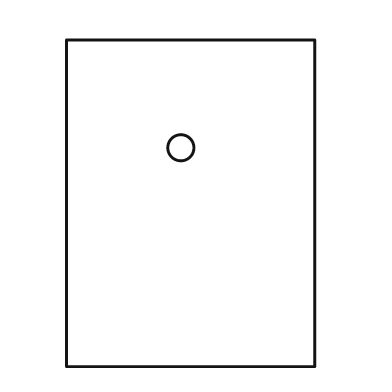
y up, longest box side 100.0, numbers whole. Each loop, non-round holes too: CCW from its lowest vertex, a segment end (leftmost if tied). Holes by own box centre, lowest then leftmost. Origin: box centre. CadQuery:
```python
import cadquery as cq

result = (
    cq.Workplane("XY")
    .moveTo(-38.0, -50.0)
    .lineTo(38.0, -50.0)
    .lineTo(38.0, 50.0)
    .lineTo(-38.0, 50.0)
    .close()
    .moveTo(-3.0, 17.0)
    .circle(4.0)
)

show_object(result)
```